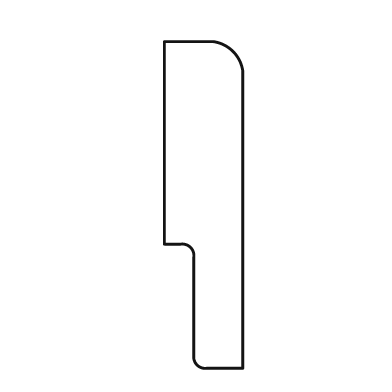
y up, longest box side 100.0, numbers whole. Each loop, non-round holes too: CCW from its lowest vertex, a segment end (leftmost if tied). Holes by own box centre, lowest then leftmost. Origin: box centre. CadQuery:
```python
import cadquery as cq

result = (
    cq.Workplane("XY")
    .moveTo(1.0, -50.0)
    .lineTo(12.0, -50.0)
    .lineTo(12.0, 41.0)
    .threePointArc((9.0, 47.0), (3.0, 50.0))
    .lineTo(-12.0, 50.0)
    .lineTo(-12.0, -12.0)
    .lineTo(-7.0, -12.0)
    .threePointArc((-4.0, -13.0), (-3.0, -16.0))
    .lineTo(-3.0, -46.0)
    .threePointArc((-2.0, -49.0), (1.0, -50.0))
    .close()
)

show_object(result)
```